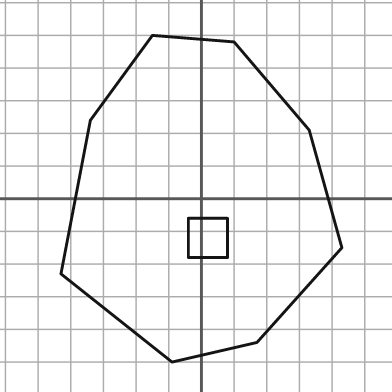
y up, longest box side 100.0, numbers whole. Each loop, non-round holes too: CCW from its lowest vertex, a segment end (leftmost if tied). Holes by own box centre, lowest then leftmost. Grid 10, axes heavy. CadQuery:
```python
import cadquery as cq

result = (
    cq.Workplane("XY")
    .moveTo(-9.0, -50.0)
    .lineTo(17.0, -44.0)
    .lineTo(43.0, -15.0)
    .lineTo(33.0, 21.0)
    .lineTo(10.0, 48.0)
    .lineTo(-15.0, 50.0)
    .lineTo(-34.0, 24.0)
    .lineTo(-43.0, -23.0)
    .close()
    .moveTo(-4.0, -18.0)
    .lineTo(8.0, -18.0)
    .lineTo(8.0, -6.0)
    .lineTo(-4.0, -6.0)
    .close()
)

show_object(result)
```